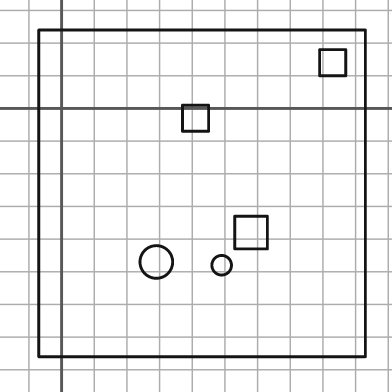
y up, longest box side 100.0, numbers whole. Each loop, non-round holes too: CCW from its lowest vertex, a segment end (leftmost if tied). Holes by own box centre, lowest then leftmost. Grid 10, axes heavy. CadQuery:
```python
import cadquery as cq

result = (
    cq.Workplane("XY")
    .moveTo(-7.0, -76.0)
    .lineTo(93.0, -76.0)
    .lineTo(93.0, 24.0)
    .lineTo(-7.0, 24.0)
    .close()
    .moveTo(49.0, -48.0)
    .circle(3.0)
    .moveTo(29.0, -47.0)
    .circle(5.0)
    .moveTo(53.0, -43.0)
    .lineTo(63.0, -43.0)
    .lineTo(63.0, -33.0)
    .lineTo(53.0, -33.0)
    .close()
    .moveTo(37.0, -7.0)
    .lineTo(45.0, -7.0)
    .lineTo(45.0, 1.0)
    .lineTo(37.0, 1.0)
    .close()
    .moveTo(79.0, 10.0)
    .lineTo(87.0, 10.0)
    .lineTo(87.0, 18.0)
    .lineTo(79.0, 18.0)
    .close()
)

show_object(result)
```